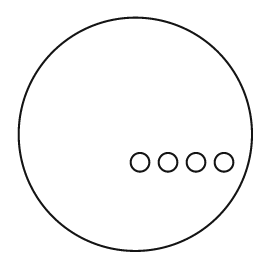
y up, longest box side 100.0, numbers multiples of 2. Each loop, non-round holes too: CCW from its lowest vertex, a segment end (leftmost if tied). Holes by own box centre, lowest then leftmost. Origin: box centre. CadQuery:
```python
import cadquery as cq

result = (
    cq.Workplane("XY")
    .moveTo(0.0, 0.0)
    .circle(50.0)
    .moveTo(2.0, -12.0)
    .circle(4.0)
    .moveTo(14.0, -12.0)
    .circle(4.0)
    .moveTo(26.0, -12.0)
    .circle(4.0)
    .moveTo(38.0, -12.0)
    .circle(4.0)
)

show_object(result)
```